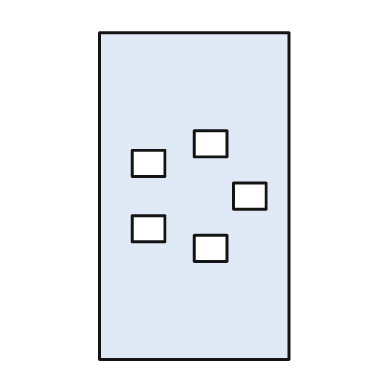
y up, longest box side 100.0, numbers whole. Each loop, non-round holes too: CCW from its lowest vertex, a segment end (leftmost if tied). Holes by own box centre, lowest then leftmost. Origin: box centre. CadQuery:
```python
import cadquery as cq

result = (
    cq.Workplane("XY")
    .moveTo(-29.0, -50.0)
    .lineTo(29.0, -50.0)
    .lineTo(29.0, 50.0)
    .lineTo(-29.0, 50.0)
    .close()
    .moveTo(0.0, -20.0)
    .lineTo(10.0, -20.0)
    .lineTo(10.0, -12.0)
    .lineTo(0.0, -12.0)
    .close()
    .moveTo(-19.0, -14.0)
    .lineTo(-9.0, -14.0)
    .lineTo(-9.0, -6.0)
    .lineTo(-19.0, -6.0)
    .close()
    .moveTo(12.0, -4.0)
    .lineTo(22.0, -4.0)
    .lineTo(22.0, 4.0)
    .lineTo(12.0, 4.0)
    .close()
    .moveTo(-19.0, 6.0)
    .lineTo(-9.0, 6.0)
    .lineTo(-9.0, 14.0)
    .lineTo(-19.0, 14.0)
    .close()
    .moveTo(0.0, 12.0)
    .lineTo(10.0, 12.0)
    .lineTo(10.0, 20.0)
    .lineTo(0.0, 20.0)
    .close()
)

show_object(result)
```